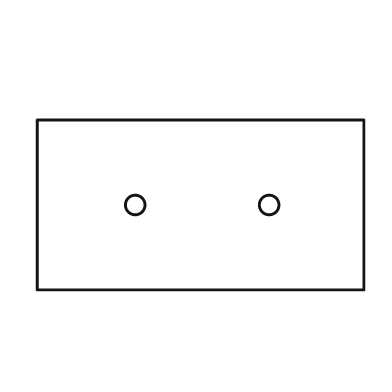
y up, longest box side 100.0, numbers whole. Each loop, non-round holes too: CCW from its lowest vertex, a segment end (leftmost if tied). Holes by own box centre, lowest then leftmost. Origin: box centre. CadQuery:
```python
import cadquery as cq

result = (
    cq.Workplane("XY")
    .moveTo(-50.0, -26.0)
    .lineTo(50.0, -26.0)
    .lineTo(50.0, 26.0)
    .lineTo(-50.0, 26.0)
    .close()
    .moveTo(-20.0, 0.0)
    .circle(3.0)
    .moveTo(21.0, 0.0)
    .circle(3.0)
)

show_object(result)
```